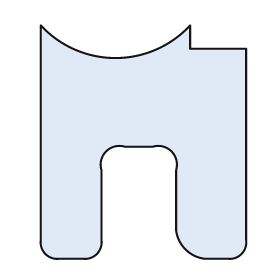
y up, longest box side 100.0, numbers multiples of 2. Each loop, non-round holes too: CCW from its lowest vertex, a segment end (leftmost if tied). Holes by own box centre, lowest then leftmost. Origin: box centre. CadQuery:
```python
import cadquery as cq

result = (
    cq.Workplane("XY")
    .moveTo(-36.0, -50.0)
    .lineTo(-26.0, -50.0)
    .threePointArc((-20.0, -48.0), (-18.0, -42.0))
    .lineTo(-18.0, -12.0)
    .threePointArc((-16.0, -4.0), (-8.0, -2.0))
    .lineTo(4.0, -2.0)
    .threePointArc((12.0, -4.0), (14.0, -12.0))
    .lineTo(14.0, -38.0)
    .threePointArc((18.0, -46.0), (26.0, -50.0))
    .lineTo(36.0, -50.0)
    .threePointArc((42.0, -48.0), (44.0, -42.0))
    .lineTo(44.0, 40.0)
    .lineTo(20.0, 40.0)
    .lineTo(20.0, 50.0)
    .threePointArc((-12.0, 36.0), (-44.0, 50.0))
    .lineTo(-44.0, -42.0)
    .threePointArc((-42.0, -48.0), (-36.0, -50.0))
    .close()
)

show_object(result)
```